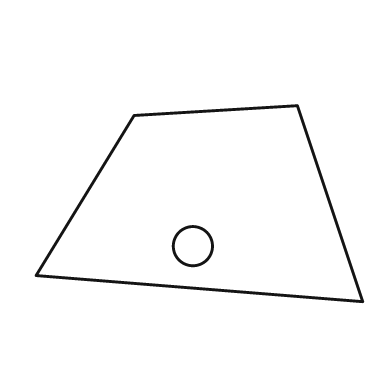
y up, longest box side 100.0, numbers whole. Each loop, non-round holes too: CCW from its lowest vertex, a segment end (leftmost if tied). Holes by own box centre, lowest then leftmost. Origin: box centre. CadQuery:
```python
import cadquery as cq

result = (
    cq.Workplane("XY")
    .moveTo(50.0, -30.0)
    .lineTo(30.0, 30.0)
    .lineTo(-20.0, 27.0)
    .lineTo(-50.0, -22.0)
    .close()
    .moveTo(-2.0, -13.0)
    .circle(6.0)
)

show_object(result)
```